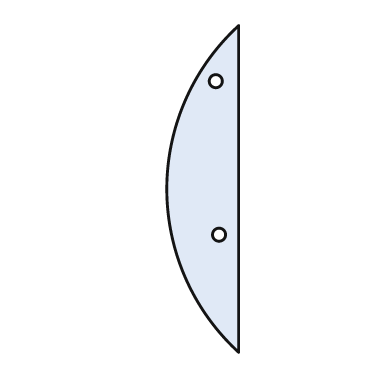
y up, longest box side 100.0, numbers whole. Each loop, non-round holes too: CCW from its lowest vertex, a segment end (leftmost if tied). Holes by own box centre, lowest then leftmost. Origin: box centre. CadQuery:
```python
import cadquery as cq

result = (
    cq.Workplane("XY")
    .moveTo(11.0, -50.0)
    .lineTo(11.0, 50.0)
    .threePointArc((-11.0, 0.0), (11.0, -50.0))
    .close()
    .moveTo(5.0, -14.0)
    .circle(2.0)
    .moveTo(4.0, 33.0)
    .circle(2.0)
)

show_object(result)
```